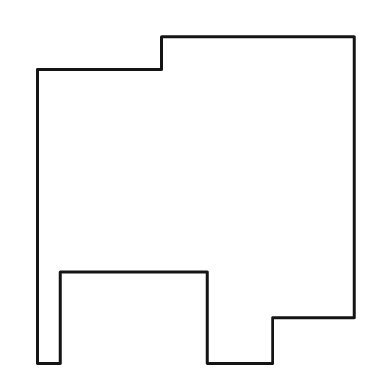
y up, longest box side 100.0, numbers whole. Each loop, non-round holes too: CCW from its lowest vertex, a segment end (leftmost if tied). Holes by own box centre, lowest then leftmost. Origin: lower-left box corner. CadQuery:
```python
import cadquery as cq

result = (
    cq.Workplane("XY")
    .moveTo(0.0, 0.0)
    .lineTo(7.0, 0.0)
    .lineTo(7.0, 28.0)
    .lineTo(52.0, 28.0)
    .lineTo(52.0, 0.0)
    .lineTo(72.0, 0.0)
    .lineTo(72.0, 14.0)
    .lineTo(97.0, 14.0)
    .lineTo(97.0, 100.0)
    .lineTo(38.0, 100.0)
    .lineTo(38.0, 90.0)
    .lineTo(0.0, 90.0)
    .close()
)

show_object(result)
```